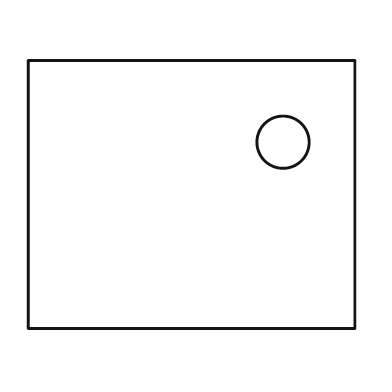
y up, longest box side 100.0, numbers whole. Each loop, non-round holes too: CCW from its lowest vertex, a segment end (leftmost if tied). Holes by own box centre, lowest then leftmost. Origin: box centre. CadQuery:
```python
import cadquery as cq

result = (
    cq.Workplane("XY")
    .moveTo(-50.0, -41.0)
    .lineTo(50.0, -41.0)
    .lineTo(50.0, 41.0)
    .lineTo(-50.0, 41.0)
    .close()
    .moveTo(28.0, 16.0)
    .circle(8.0)
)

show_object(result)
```